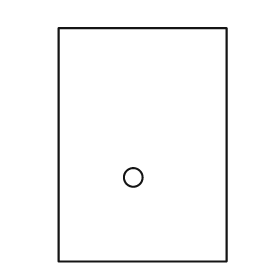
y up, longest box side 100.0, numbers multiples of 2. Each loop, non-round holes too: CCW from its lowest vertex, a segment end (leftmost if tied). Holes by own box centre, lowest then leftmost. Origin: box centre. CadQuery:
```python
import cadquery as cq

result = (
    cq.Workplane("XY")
    .moveTo(-36.0, -50.0)
    .lineTo(36.0, -50.0)
    .lineTo(36.0, 50.0)
    .lineTo(-36.0, 50.0)
    .close()
    .moveTo(-4.0, -14.0)
    .circle(4.0)
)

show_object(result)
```